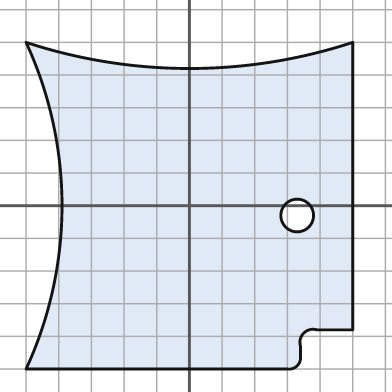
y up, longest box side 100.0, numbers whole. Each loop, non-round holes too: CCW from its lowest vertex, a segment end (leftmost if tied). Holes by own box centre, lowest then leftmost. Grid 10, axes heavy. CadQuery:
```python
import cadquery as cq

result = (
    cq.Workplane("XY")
    .moveTo(-50.0, -50.0)
    .lineTo(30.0, -50.0)
    .threePointArc((33.0, -49.0), (34.0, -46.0))
    .lineTo(34.0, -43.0)
    .threePointArc((35.0, -39.0), (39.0, -38.0))
    .lineTo(50.0, -38.0)
    .lineTo(50.0, 50.0)
    .threePointArc((0.0, 42.0), (-50.0, 50.0))
    .threePointArc((-39.0, 0.0), (-50.0, -50.0))
    .close()
    .moveTo(33.0, -3.0)
    .circle(5.0)
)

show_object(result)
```